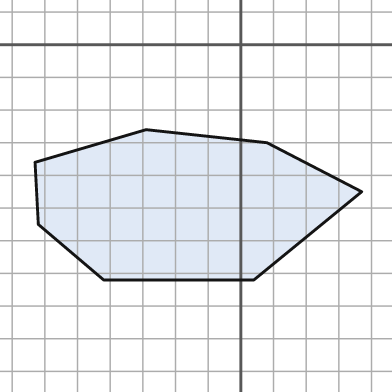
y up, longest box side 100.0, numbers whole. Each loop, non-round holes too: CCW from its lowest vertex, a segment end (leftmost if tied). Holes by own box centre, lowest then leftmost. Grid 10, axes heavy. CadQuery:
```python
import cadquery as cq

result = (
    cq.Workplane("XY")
    .moveTo(-42.0, -72.0)
    .lineTo(4.0, -72.0)
    .lineTo(37.0, -45.0)
    .lineTo(8.0, -30.0)
    .lineTo(-29.0, -26.0)
    .lineTo(-63.0, -36.0)
    .lineTo(-62.0, -55.0)
    .close()
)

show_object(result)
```